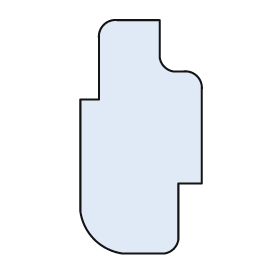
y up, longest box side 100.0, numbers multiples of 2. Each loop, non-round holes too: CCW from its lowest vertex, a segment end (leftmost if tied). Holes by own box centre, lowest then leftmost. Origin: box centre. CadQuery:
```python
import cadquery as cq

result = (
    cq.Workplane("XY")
    .moveTo(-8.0, -50.0)
    .lineTo(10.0, -50.0)
    .threePointArc((14.0, -48.0), (16.0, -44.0))
    .lineTo(16.0, -20.0)
    .lineTo(26.0, -20.0)
    .lineTo(26.0, 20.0)
    .threePointArc((24.0, 26.0), (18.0, 28.0))
    .lineTo(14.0, 28.0)
    .threePointArc((10.0, 30.0), (8.0, 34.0))
    .lineTo(8.0, 50.0)
    .lineTo(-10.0, 50.0)
    .threePointArc((-16.0, 48.0), (-18.0, 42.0))
    .lineTo(-18.0, 16.0)
    .lineTo(-26.0, 16.0)
    .lineTo(-26.0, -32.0)
    .threePointArc((-20.0, -44.0), (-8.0, -50.0))
    .close()
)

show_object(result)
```